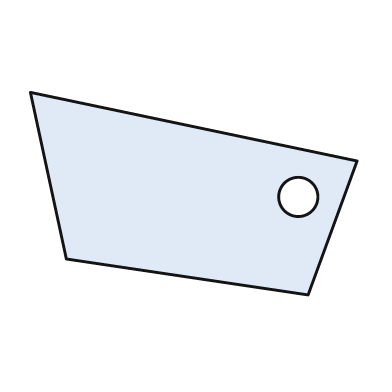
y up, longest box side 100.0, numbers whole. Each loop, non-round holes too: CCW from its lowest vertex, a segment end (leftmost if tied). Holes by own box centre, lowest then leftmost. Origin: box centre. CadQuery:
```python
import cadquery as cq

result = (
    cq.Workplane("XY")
    .moveTo(35.0, -31.0)
    .lineTo(50.0, 10.0)
    .lineTo(-50.0, 31.0)
    .lineTo(-39.0, -20.0)
    .close()
    .moveTo(32.0, -1.0)
    .circle(6.0)
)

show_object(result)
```